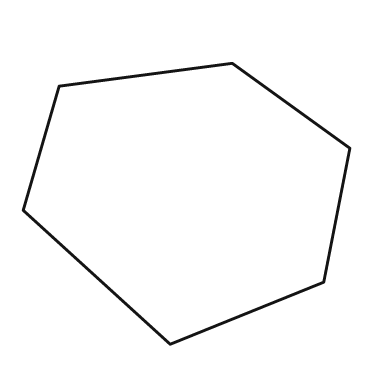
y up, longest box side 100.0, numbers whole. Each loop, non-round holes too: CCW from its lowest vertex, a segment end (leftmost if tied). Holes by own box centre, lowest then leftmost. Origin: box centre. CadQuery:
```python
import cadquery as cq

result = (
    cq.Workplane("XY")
    .moveTo(-5.0, -43.0)
    .lineTo(42.0, -24.0)
    .lineTo(50.0, 17.0)
    .lineTo(14.0, 43.0)
    .lineTo(-39.0, 36.0)
    .lineTo(-50.0, -2.0)
    .close()
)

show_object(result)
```